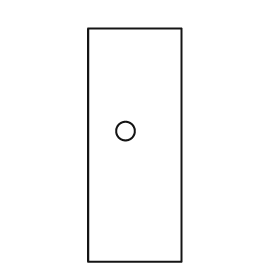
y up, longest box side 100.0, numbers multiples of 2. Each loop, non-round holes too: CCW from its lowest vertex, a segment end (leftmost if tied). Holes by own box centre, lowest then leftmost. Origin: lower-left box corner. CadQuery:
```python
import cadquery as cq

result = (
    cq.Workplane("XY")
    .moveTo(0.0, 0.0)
    .lineTo(40.0, 0.0)
    .lineTo(40.0, 100.0)
    .lineTo(0.0, 100.0)
    .close()
    .moveTo(16.0, 56.0)
    .circle(4.0)
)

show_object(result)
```